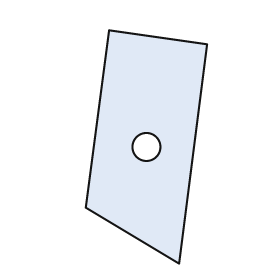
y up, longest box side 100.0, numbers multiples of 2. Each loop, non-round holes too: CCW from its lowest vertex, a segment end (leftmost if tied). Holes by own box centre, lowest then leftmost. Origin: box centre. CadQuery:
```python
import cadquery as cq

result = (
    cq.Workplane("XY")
    .moveTo(14.0, -50.0)
    .lineTo(26.0, 44.0)
    .lineTo(-16.0, 50.0)
    .lineTo(-26.0, -26.0)
    .close()
    .moveTo(0.0, 0.0)
    .circle(6.0)
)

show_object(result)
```